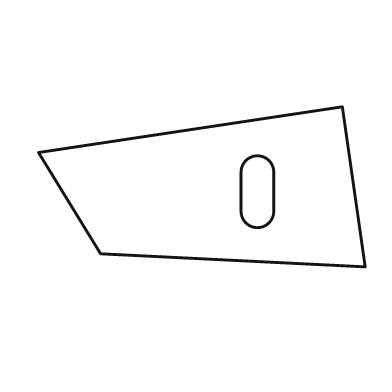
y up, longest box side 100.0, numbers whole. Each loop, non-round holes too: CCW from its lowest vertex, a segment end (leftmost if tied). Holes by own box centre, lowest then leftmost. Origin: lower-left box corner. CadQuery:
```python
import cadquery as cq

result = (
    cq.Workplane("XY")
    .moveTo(100.0, 0.0)
    .lineTo(93.0, 49.0)
    .lineTo(0.0, 35.0)
    .lineTo(19.0, 4.0)
    .close()
    .moveTo(62.0, 17.0)
    .threePointArc((67.0, 12.0), (72.0, 17.0))
    .lineTo(72.0, 29.0)
    .threePointArc((67.0, 34.0), (62.0, 29.0))
    .close()
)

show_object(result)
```